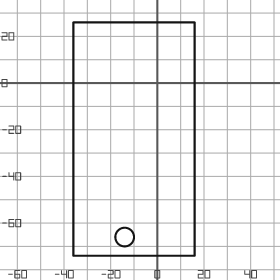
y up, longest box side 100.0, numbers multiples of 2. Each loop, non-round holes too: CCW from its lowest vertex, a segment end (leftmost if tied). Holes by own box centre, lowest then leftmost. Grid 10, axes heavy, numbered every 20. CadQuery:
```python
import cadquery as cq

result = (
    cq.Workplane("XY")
    .moveTo(-36.0, -74.0)
    .lineTo(16.0, -74.0)
    .lineTo(16.0, 26.0)
    .lineTo(-36.0, 26.0)
    .close()
    .moveTo(-14.0, -66.0)
    .circle(4.0)
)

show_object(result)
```